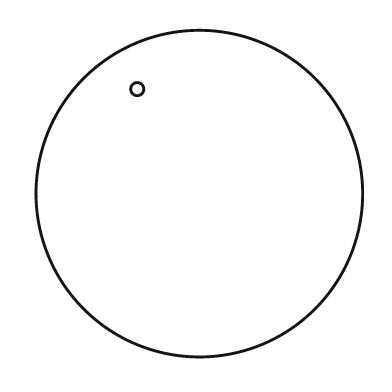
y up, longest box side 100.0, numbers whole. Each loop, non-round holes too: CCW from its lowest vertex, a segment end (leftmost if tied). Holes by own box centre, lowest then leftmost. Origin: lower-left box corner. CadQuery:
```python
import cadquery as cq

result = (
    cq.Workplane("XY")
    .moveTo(50.0, 50.0)
    .circle(50.0)
    .moveTo(31.0, 82.0)
    .circle(2.0)
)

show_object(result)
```